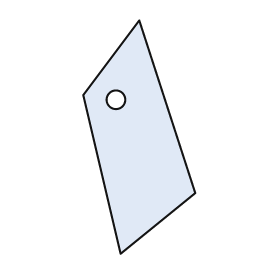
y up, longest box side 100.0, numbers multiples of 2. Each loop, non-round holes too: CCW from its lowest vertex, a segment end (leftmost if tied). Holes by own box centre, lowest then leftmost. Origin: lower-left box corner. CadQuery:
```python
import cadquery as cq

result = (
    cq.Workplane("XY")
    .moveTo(16.0, 0.0)
    .lineTo(48.0, 26.0)
    .lineTo(24.0, 100.0)
    .lineTo(0.0, 68.0)
    .close()
    .moveTo(14.0, 66.0)
    .circle(4.0)
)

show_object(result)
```